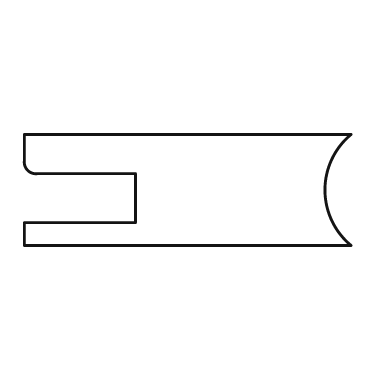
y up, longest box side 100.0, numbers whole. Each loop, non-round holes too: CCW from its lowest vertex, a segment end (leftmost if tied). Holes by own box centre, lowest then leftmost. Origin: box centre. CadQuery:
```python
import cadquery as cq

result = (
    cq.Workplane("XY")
    .moveTo(-50.0, -17.0)
    .lineTo(50.0, -17.0)
    .threePointArc((42.0, 0.0), (50.0, 17.0))
    .lineTo(-50.0, 17.0)
    .lineTo(-50.0, 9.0)
    .threePointArc((-49.0, 6.0), (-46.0, 5.0))
    .lineTo(-16.0, 5.0)
    .lineTo(-16.0, -10.0)
    .lineTo(-50.0, -10.0)
    .close()
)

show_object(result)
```